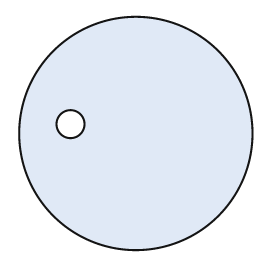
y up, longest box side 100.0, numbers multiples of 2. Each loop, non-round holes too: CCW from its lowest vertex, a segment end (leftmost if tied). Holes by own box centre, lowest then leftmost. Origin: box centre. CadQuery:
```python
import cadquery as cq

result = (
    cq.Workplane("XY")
    .moveTo(0.0, 0.0)
    .circle(50.0)
    .moveTo(-28.0, 4.0)
    .circle(6.0)
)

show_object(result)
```